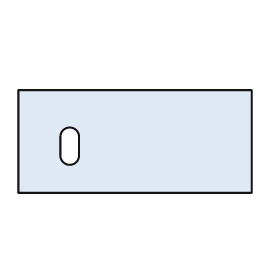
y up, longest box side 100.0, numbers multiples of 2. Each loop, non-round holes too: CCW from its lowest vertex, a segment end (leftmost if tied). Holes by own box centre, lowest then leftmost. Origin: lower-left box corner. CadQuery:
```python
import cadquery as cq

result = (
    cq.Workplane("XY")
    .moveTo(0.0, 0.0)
    .lineTo(100.0, 0.0)
    .lineTo(100.0, 44.0)
    .lineTo(0.0, 44.0)
    .close()
    .moveTo(18.0, 16.0)
    .threePointArc((22.0, 12.0), (26.0, 16.0))
    .lineTo(26.0, 24.0)
    .threePointArc((22.0, 28.0), (18.0, 24.0))
    .close()
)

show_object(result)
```